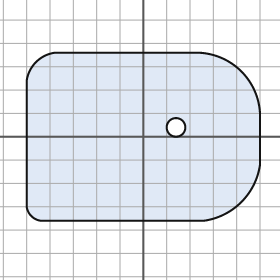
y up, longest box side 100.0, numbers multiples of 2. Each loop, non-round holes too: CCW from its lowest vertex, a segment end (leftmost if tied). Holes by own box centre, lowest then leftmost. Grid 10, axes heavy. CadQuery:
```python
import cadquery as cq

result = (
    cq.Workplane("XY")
    .moveTo(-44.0, -36.0)
    .lineTo(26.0, -36.0)
    .threePointArc((42.0, -28.0), (50.0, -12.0))
    .lineTo(50.0, 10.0)
    .threePointArc((42.0, 28.0), (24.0, 36.0))
    .lineTo(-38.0, 36.0)
    .threePointArc((-46.0, 32.0), (-50.0, 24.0))
    .lineTo(-50.0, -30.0)
    .threePointArc((-48.0, -34.0), (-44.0, -36.0))
    .close()
    .moveTo(14.0, 4.0)
    .circle(4.0)
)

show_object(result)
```